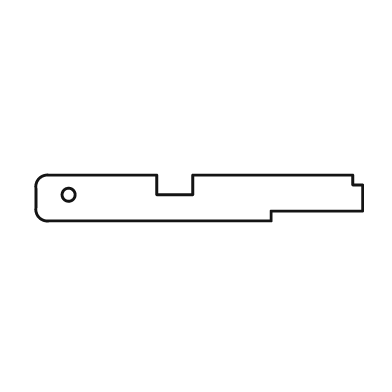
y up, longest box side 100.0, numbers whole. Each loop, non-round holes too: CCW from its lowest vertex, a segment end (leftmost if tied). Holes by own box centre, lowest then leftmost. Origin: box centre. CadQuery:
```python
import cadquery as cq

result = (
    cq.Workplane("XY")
    .moveTo(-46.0, -7.0)
    .lineTo(22.0, -7.0)
    .lineTo(22.0, -4.0)
    .lineTo(50.0, -4.0)
    .lineTo(50.0, 4.0)
    .lineTo(47.0, 4.0)
    .lineTo(47.0, 7.0)
    .lineTo(-2.0, 7.0)
    .lineTo(-2.0, 1.0)
    .lineTo(-13.0, 1.0)
    .lineTo(-13.0, 7.0)
    .lineTo(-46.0, 7.0)
    .threePointArc((-49.0, 6.0), (-50.0, 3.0))
    .lineTo(-50.0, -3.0)
    .threePointArc((-49.0, -6.0), (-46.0, -7.0))
    .close()
    .moveTo(-40.0, 1.0)
    .circle(2.0)
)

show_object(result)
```